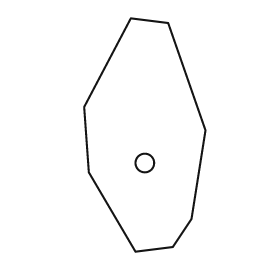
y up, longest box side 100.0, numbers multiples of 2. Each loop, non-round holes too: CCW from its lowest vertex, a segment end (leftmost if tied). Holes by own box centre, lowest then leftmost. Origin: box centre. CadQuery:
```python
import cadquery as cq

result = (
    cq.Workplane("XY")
    .moveTo(-4.0, -50.0)
    .lineTo(12.0, -48.0)
    .lineTo(20.0, -36.0)
    .lineTo(26.0, 2.0)
    .lineTo(10.0, 48.0)
    .lineTo(-6.0, 50.0)
    .lineTo(-26.0, 12.0)
    .lineTo(-24.0, -16.0)
    .close()
    .moveTo(0.0, -12.0)
    .circle(4.0)
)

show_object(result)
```